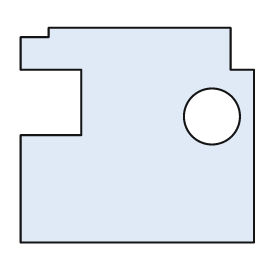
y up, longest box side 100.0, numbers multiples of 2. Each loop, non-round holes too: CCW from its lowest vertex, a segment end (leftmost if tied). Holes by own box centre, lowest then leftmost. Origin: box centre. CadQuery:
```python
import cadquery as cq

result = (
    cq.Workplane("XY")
    .moveTo(-50.0, -46.0)
    .lineTo(50.0, -46.0)
    .lineTo(50.0, 28.0)
    .lineTo(40.0, 28.0)
    .lineTo(40.0, 46.0)
    .lineTo(-38.0, 46.0)
    .lineTo(-38.0, 42.0)
    .lineTo(-50.0, 42.0)
    .lineTo(-50.0, 28.0)
    .lineTo(-24.0, 28.0)
    .lineTo(-24.0, 0.0)
    .lineTo(-50.0, 0.0)
    .close()
    .moveTo(32.0, 8.0)
    .circle(12.0)
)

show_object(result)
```